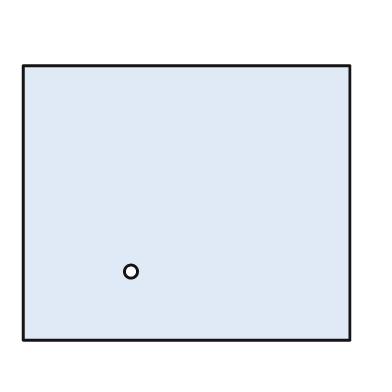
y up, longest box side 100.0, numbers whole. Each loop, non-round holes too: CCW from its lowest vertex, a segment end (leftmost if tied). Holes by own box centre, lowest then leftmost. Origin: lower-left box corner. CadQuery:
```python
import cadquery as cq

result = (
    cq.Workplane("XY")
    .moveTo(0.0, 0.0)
    .lineTo(100.0, 0.0)
    .lineTo(100.0, 84.0)
    .lineTo(0.0, 84.0)
    .close()
    .moveTo(33.0, 21.0)
    .circle(2.0)
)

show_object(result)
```